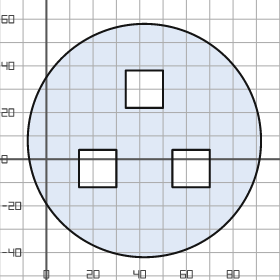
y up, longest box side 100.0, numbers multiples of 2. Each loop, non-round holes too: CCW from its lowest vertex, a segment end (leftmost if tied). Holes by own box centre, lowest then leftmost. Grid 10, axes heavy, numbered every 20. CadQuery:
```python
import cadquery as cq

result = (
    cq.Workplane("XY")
    .moveTo(42.0, 8.0)
    .circle(50.0)
    .moveTo(14.0, -12.0)
    .lineTo(30.0, -12.0)
    .lineTo(30.0, 4.0)
    .lineTo(14.0, 4.0)
    .close()
    .moveTo(54.0, -12.0)
    .lineTo(70.0, -12.0)
    .lineTo(70.0, 4.0)
    .lineTo(54.0, 4.0)
    .close()
    .moveTo(34.0, 22.0)
    .lineTo(50.0, 22.0)
    .lineTo(50.0, 38.0)
    .lineTo(34.0, 38.0)
    .close()
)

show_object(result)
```